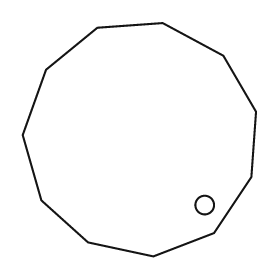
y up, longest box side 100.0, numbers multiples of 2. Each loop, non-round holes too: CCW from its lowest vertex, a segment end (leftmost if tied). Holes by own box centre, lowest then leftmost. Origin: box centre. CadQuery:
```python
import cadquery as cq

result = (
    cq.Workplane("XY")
    .moveTo(6.0, -50.0)
    .lineTo(32.0, -40.0)
    .lineTo(48.0, -16.0)
    .lineTo(50.0, 12.0)
    .lineTo(36.0, 36.0)
    .lineTo(10.0, 50.0)
    .lineTo(-18.0, 48.0)
    .lineTo(-40.0, 30.0)
    .lineTo(-50.0, 2.0)
    .lineTo(-42.0, -26.0)
    .lineTo(-22.0, -44.0)
    .close()
    .moveTo(28.0, -28.0)
    .circle(4.0)
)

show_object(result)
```